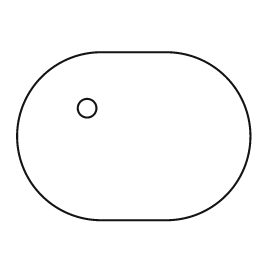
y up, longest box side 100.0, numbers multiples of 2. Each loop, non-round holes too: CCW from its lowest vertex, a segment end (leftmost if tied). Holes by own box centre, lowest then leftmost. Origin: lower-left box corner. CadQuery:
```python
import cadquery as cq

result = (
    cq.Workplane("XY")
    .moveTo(36.0, 0.0)
    .lineTo(64.0, 0.0)
    .threePointArc((100.0, 36.0), (64.0, 72.0))
    .lineTo(36.0, 72.0)
    .threePointArc((0.0, 36.0), (36.0, 0.0))
    .close()
    .moveTo(30.0, 48.0)
    .circle(4.0)
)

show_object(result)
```